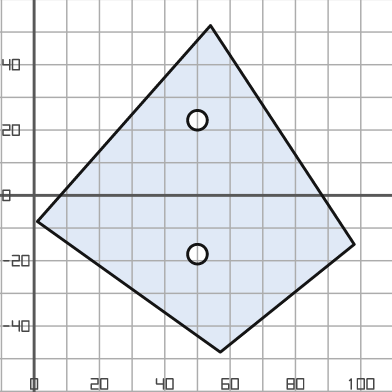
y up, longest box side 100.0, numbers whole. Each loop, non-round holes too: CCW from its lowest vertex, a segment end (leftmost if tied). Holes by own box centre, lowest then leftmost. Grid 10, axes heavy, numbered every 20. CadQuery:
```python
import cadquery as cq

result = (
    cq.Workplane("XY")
    .moveTo(57.0, -48.0)
    .lineTo(98.0, -15.0)
    .lineTo(54.0, 52.0)
    .lineTo(1.0, -8.0)
    .close()
    .moveTo(50.0, -18.0)
    .circle(3.0)
    .moveTo(50.0, 23.0)
    .circle(3.0)
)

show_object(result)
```